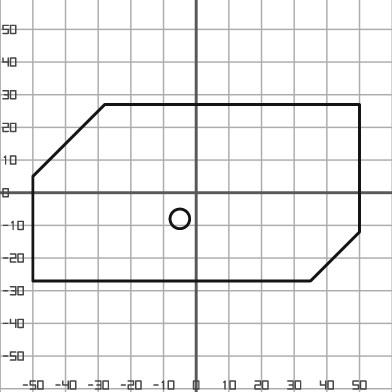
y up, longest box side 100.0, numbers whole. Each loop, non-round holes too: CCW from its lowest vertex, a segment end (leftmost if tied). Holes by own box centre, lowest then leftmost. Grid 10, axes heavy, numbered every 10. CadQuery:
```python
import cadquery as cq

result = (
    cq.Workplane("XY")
    .moveTo(-50.0, -27.0)
    .lineTo(35.0, -27.0)
    .lineTo(50.0, -12.0)
    .lineTo(50.0, 27.0)
    .lineTo(-28.0, 27.0)
    .lineTo(-50.0, 5.0)
    .close()
    .moveTo(-5.0, -8.0)
    .circle(3.0)
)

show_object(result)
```